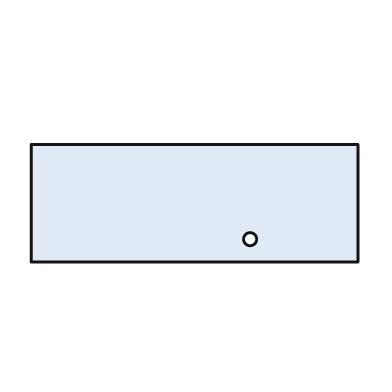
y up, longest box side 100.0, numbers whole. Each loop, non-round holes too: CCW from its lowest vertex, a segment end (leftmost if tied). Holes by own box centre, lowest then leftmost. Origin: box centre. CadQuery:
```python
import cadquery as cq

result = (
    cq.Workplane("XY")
    .moveTo(-50.0, -18.0)
    .lineTo(50.0, -18.0)
    .lineTo(50.0, 18.0)
    .lineTo(-50.0, 18.0)
    .close()
    .moveTo(17.0, -11.0)
    .circle(2.0)
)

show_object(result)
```